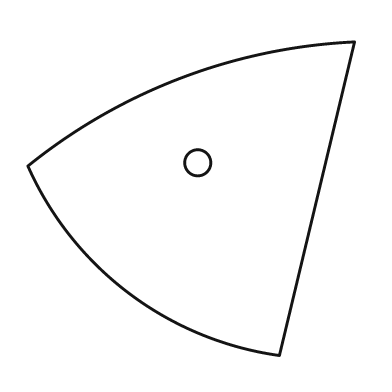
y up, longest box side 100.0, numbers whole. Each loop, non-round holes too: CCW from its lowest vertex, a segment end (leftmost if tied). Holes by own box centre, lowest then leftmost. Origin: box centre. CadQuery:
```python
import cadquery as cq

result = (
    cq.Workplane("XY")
    .moveTo(27.0, -48.0)
    .lineTo(50.0, 48.0)
    .threePointArc((-3.0, 37.0), (-50.0, 10.0))
    .threePointArc((-19.0, -29.0), (27.0, -48.0))
    .close()
    .moveTo(2.0, 11.0)
    .circle(4.0)
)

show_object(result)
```